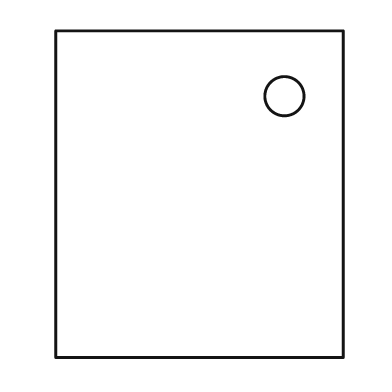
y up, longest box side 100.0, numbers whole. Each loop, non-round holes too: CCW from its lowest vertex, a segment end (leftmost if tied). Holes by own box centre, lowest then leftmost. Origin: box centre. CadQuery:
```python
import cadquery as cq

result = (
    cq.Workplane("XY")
    .moveTo(-44.0, -50.0)
    .lineTo(44.0, -50.0)
    .lineTo(44.0, 50.0)
    .lineTo(-44.0, 50.0)
    .close()
    .moveTo(26.0, 30.0)
    .circle(6.0)
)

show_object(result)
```